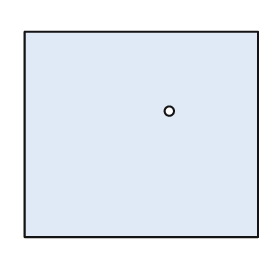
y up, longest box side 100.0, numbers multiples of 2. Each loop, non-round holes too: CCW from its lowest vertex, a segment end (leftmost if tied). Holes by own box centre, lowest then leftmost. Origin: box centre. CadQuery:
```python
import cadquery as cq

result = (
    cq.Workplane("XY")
    .moveTo(-50.0, -44.0)
    .lineTo(50.0, -44.0)
    .lineTo(50.0, 44.0)
    .lineTo(-50.0, 44.0)
    .close()
    .moveTo(12.0, 10.0)
    .circle(2.0)
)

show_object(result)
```